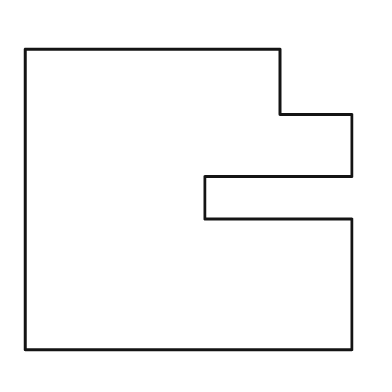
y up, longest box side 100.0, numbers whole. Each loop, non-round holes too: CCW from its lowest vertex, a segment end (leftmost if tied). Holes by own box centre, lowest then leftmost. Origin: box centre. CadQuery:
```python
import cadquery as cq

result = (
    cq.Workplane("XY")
    .moveTo(-50.0, -46.0)
    .lineTo(50.0, -46.0)
    .lineTo(50.0, -6.0)
    .lineTo(5.0, -6.0)
    .lineTo(5.0, 7.0)
    .lineTo(50.0, 7.0)
    .lineTo(50.0, 26.0)
    .lineTo(28.0, 26.0)
    .lineTo(28.0, 46.0)
    .lineTo(-50.0, 46.0)
    .close()
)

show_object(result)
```